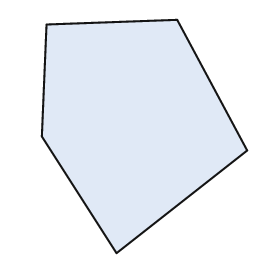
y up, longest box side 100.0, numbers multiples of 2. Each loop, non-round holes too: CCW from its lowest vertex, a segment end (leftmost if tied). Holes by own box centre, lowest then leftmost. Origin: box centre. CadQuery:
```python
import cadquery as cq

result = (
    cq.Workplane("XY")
    .moveTo(-12.0, -50.0)
    .lineTo(44.0, -6.0)
    .lineTo(14.0, 50.0)
    .lineTo(-42.0, 48.0)
    .lineTo(-44.0, 0.0)
    .close()
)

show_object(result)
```